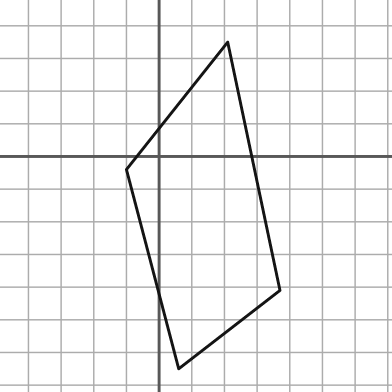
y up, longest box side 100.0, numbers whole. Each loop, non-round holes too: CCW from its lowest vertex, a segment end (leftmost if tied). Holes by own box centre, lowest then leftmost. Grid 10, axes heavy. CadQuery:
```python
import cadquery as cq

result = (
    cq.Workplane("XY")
    .moveTo(6.0, -65.0)
    .lineTo(37.0, -41.0)
    .lineTo(21.0, 35.0)
    .lineTo(-10.0, -4.0)
    .close()
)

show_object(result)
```